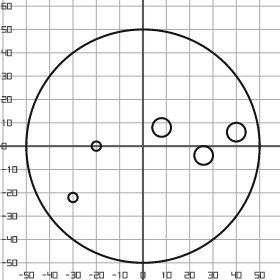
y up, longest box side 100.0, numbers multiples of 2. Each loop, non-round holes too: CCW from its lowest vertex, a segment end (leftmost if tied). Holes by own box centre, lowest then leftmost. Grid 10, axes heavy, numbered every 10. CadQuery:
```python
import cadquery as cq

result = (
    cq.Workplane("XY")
    .moveTo(0.0, 0.0)
    .circle(50.0)
    .moveTo(-30.0, -22.0)
    .circle(2.0)
    .moveTo(26.0, -4.0)
    .circle(4.0)
    .moveTo(-20.0, 0.0)
    .circle(2.0)
    .moveTo(40.0, 6.0)
    .circle(4.0)
    .moveTo(8.0, 8.0)
    .circle(4.0)
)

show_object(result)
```